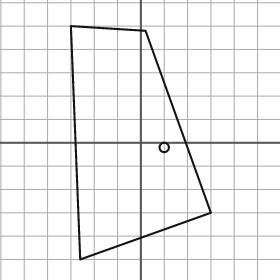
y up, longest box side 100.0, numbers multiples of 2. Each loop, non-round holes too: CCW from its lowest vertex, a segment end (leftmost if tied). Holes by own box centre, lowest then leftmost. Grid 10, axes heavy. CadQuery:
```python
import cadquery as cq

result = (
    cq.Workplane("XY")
    .moveTo(-26.0, -50.0)
    .lineTo(30.0, -30.0)
    .lineTo(2.0, 48.0)
    .lineTo(-30.0, 50.0)
    .close()
    .moveTo(10.0, -2.0)
    .circle(2.0)
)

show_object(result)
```